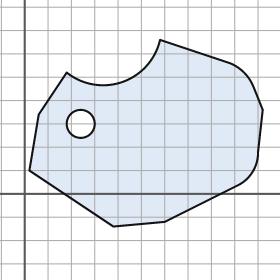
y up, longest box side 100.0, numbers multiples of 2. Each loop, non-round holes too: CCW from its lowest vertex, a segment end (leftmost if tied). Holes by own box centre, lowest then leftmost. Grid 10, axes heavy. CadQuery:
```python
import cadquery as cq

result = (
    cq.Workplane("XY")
    .moveTo(38.0, -14.0)
    .lineTo(60.0, -12.0)
    .lineTo(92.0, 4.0)
    .threePointArc((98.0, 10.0), (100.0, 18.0))
    .lineTo(102.0, 36.0)
    .lineTo(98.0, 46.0)
    .threePointArc((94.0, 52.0), (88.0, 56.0))
    .lineTo(58.0, 66.0)
    .threePointArc((42.0, 48.0), (18.0, 52.0))
    .lineTo(6.0, 34.0)
    .lineTo(2.0, 10.0)
    .close()
    .moveTo(24.0, 30.0)
    .circle(6.0)
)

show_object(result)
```